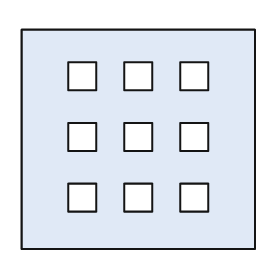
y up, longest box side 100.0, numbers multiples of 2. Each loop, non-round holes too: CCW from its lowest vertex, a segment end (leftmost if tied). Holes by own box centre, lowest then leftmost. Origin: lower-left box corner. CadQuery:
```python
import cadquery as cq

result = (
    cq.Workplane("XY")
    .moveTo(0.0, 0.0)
    .lineTo(100.0, 0.0)
    .lineTo(100.0, 94.0)
    .lineTo(0.0, 94.0)
    .close()
    .moveTo(20.0, 16.0)
    .lineTo(32.0, 16.0)
    .lineTo(32.0, 28.0)
    .lineTo(20.0, 28.0)
    .close()
    .moveTo(44.0, 16.0)
    .lineTo(56.0, 16.0)
    .lineTo(56.0, 28.0)
    .lineTo(44.0, 28.0)
    .close()
    .moveTo(68.0, 16.0)
    .lineTo(80.0, 16.0)
    .lineTo(80.0, 28.0)
    .lineTo(68.0, 28.0)
    .close()
    .moveTo(20.0, 42.0)
    .lineTo(32.0, 42.0)
    .lineTo(32.0, 54.0)
    .lineTo(20.0, 54.0)
    .close()
    .moveTo(44.0, 42.0)
    .lineTo(56.0, 42.0)
    .lineTo(56.0, 54.0)
    .lineTo(44.0, 54.0)
    .close()
    .moveTo(68.0, 42.0)
    .lineTo(80.0, 42.0)
    .lineTo(80.0, 54.0)
    .lineTo(68.0, 54.0)
    .close()
    .moveTo(20.0, 68.0)
    .lineTo(32.0, 68.0)
    .lineTo(32.0, 80.0)
    .lineTo(20.0, 80.0)
    .close()
    .moveTo(44.0, 68.0)
    .lineTo(56.0, 68.0)
    .lineTo(56.0, 80.0)
    .lineTo(44.0, 80.0)
    .close()
    .moveTo(68.0, 68.0)
    .lineTo(80.0, 68.0)
    .lineTo(80.0, 80.0)
    .lineTo(68.0, 80.0)
    .close()
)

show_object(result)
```